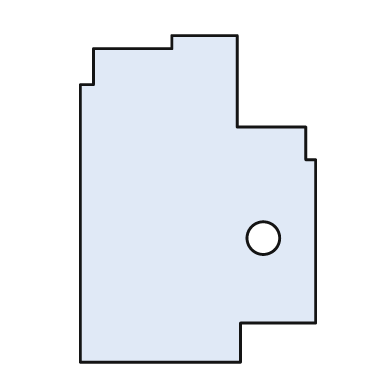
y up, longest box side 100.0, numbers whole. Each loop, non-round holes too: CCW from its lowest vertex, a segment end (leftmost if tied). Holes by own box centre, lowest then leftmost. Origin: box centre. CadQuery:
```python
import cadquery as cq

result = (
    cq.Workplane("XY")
    .moveTo(-36.0, -50.0)
    .lineTo(13.0, -50.0)
    .lineTo(13.0, -38.0)
    .lineTo(36.0, -38.0)
    .lineTo(36.0, 12.0)
    .lineTo(33.0, 12.0)
    .lineTo(33.0, 22.0)
    .lineTo(12.0, 22.0)
    .lineTo(12.0, 50.0)
    .lineTo(-8.0, 50.0)
    .lineTo(-8.0, 46.0)
    .lineTo(-32.0, 46.0)
    .lineTo(-32.0, 35.0)
    .lineTo(-36.0, 35.0)
    .close()
    .moveTo(20.0, -12.0)
    .circle(5.0)
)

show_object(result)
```